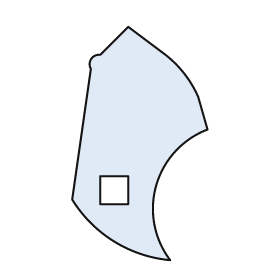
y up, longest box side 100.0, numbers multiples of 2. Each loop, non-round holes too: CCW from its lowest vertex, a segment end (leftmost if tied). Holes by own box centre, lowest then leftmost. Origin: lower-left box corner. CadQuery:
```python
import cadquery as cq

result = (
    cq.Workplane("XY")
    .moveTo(42.0, 0.0)
    .threePointArc((36.0, 32.0), (58.0, 56.0))
    .lineTo(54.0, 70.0)
    .threePointArc((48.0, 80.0), (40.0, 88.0))
    .lineTo(24.0, 100.0)
    .lineTo(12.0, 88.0)
    .threePointArc((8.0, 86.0), (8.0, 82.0))
    .lineTo(0.0, 26.0)
    .threePointArc((18.0, 8.0), (42.0, 0.0))
    .close()
    .moveTo(12.0, 24.0)
    .lineTo(24.0, 24.0)
    .lineTo(24.0, 36.0)
    .lineTo(12.0, 36.0)
    .close()
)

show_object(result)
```